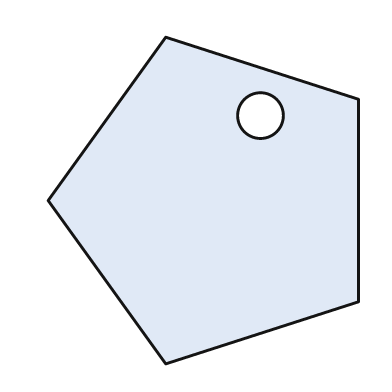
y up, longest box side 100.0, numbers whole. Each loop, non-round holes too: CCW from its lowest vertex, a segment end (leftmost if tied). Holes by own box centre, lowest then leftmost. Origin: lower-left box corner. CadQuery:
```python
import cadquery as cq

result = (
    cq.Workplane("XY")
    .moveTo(36.0, 0.0)
    .lineTo(95.0, 19.0)
    .lineTo(95.0, 81.0)
    .lineTo(36.0, 100.0)
    .lineTo(0.0, 50.0)
    .close()
    .moveTo(65.0, 76.0)
    .circle(7.0)
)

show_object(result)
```